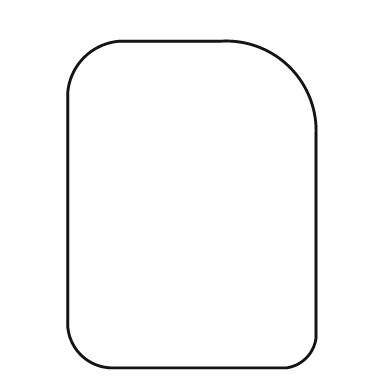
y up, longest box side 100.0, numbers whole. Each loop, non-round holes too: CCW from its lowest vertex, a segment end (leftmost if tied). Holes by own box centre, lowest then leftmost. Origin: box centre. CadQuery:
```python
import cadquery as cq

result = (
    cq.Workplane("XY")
    .moveTo(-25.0, -50.0)
    .lineTo(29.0, -50.0)
    .threePointArc((35.0, -47.0), (38.0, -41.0))
    .lineTo(38.0, 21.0)
    .threePointArc((30.0, 42.0), (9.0, 50.0))
    .lineTo(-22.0, 50.0)
    .threePointArc((-33.0, 45.0), (-38.0, 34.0))
    .lineTo(-38.0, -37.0)
    .threePointArc((-34.0, -46.0), (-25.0, -50.0))
    .close()
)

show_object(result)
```